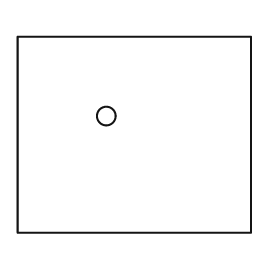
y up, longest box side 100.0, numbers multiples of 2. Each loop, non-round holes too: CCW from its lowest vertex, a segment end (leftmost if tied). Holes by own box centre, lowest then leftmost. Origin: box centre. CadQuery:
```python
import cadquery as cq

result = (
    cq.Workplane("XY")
    .moveTo(-50.0, -42.0)
    .lineTo(50.0, -42.0)
    .lineTo(50.0, 42.0)
    .lineTo(-50.0, 42.0)
    .close()
    .moveTo(-12.0, 8.0)
    .circle(4.0)
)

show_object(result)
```